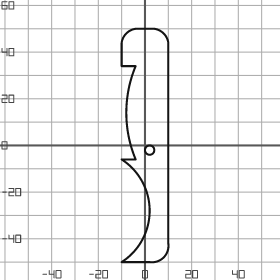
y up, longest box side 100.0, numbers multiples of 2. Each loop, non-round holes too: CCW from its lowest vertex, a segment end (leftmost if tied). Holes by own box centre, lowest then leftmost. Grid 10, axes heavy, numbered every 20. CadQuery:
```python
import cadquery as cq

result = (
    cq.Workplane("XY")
    .moveTo(-10.0, -50.0)
    .lineTo(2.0, -50.0)
    .threePointArc((8.0, -48.0), (10.0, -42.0))
    .lineTo(10.0, 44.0)
    .threePointArc((8.0, 48.0), (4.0, 50.0))
    .lineTo(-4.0, 50.0)
    .threePointArc((-8.0, 48.0), (-10.0, 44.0))
    .lineTo(-10.0, 34.0)
    .lineTo(-4.0, 34.0)
    .threePointArc((-8.0, 14.0), (-4.0, -6.0))
    .lineTo(-10.0, -6.0)
    .threePointArc((2.0, -28.0), (-10.0, -50.0))
    .close()
    .moveTo(2.0, -2.0)
    .circle(2.0)
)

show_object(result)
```